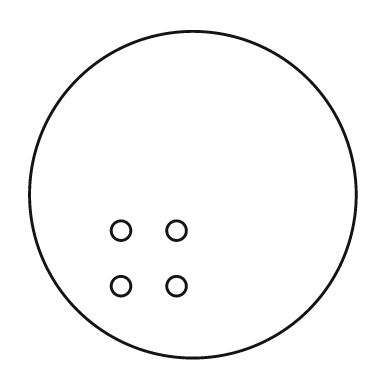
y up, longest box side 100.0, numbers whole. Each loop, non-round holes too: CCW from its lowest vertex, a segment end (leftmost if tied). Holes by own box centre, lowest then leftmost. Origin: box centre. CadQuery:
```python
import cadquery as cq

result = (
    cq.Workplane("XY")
    .moveTo(0.0, 0.0)
    .circle(50.0)
    .moveTo(-22.0, -28.0)
    .circle(3.0)
    .moveTo(-5.0, -28.0)
    .circle(3.0)
    .moveTo(-22.0, -11.0)
    .circle(3.0)
    .moveTo(-5.0, -11.0)
    .circle(3.0)
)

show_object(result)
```